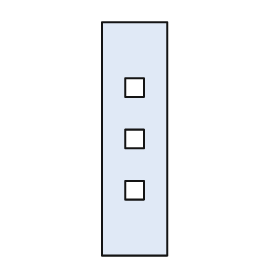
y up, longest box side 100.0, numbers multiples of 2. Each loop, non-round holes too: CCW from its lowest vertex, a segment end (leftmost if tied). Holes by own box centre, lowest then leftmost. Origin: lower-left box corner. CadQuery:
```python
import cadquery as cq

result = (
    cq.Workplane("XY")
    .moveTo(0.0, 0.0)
    .lineTo(28.0, 0.0)
    .lineTo(28.0, 100.0)
    .lineTo(0.0, 100.0)
    .close()
    .moveTo(10.0, 24.0)
    .lineTo(18.0, 24.0)
    .lineTo(18.0, 32.0)
    .lineTo(10.0, 32.0)
    .close()
    .moveTo(10.0, 46.0)
    .lineTo(18.0, 46.0)
    .lineTo(18.0, 54.0)
    .lineTo(10.0, 54.0)
    .close()
    .moveTo(10.0, 68.0)
    .lineTo(18.0, 68.0)
    .lineTo(18.0, 76.0)
    .lineTo(10.0, 76.0)
    .close()
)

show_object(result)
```